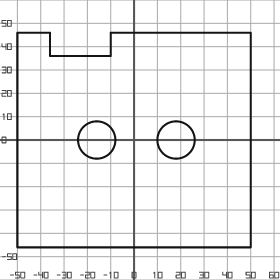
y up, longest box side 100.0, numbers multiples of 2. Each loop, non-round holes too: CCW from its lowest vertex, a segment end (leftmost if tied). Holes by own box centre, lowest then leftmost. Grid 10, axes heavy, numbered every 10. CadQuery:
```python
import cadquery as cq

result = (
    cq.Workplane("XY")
    .moveTo(-50.0, -46.0)
    .lineTo(50.0, -46.0)
    .lineTo(50.0, 46.0)
    .lineTo(-10.0, 46.0)
    .lineTo(-10.0, 36.0)
    .lineTo(-36.0, 36.0)
    .lineTo(-36.0, 46.0)
    .lineTo(-50.0, 46.0)
    .close()
    .moveTo(-16.0, 0.0)
    .circle(8.0)
    .moveTo(18.0, 0.0)
    .circle(8.0)
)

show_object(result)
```